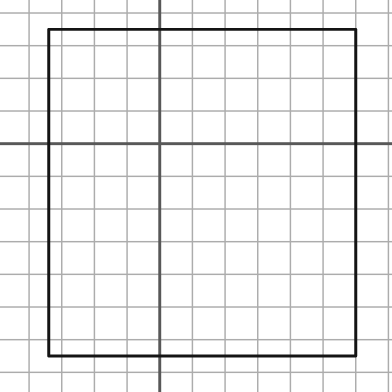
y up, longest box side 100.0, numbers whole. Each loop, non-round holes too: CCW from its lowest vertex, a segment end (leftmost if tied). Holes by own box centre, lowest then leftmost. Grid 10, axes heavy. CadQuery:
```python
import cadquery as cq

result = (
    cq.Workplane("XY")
    .moveTo(-34.0, -65.0)
    .lineTo(60.0, -65.0)
    .lineTo(60.0, 35.0)
    .lineTo(-34.0, 35.0)
    .close()
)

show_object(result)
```